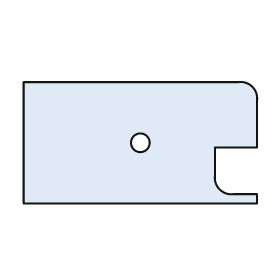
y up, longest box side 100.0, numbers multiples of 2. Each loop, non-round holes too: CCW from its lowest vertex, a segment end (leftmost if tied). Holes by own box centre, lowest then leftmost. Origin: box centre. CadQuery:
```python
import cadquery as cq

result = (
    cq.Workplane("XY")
    .moveTo(-50.0, -26.0)
    .lineTo(50.0, -26.0)
    .lineTo(50.0, -22.0)
    .lineTo(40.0, -22.0)
    .threePointArc((34.0, -20.0), (32.0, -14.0))
    .lineTo(32.0, -2.0)
    .lineTo(50.0, -2.0)
    .lineTo(50.0, 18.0)
    .threePointArc((48.0, 24.0), (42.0, 26.0))
    .lineTo(-50.0, 26.0)
    .close()
    .moveTo(0.0, 0.0)
    .circle(4.0)
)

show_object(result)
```